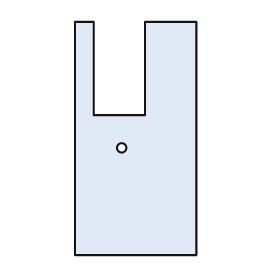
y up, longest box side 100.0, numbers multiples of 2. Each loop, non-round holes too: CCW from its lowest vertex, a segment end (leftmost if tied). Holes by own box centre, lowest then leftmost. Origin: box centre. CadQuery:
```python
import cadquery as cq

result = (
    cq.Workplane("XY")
    .moveTo(-26.0, -50.0)
    .lineTo(26.0, -50.0)
    .lineTo(26.0, 50.0)
    .lineTo(4.0, 50.0)
    .lineTo(4.0, 10.0)
    .lineTo(-18.0, 10.0)
    .lineTo(-18.0, 50.0)
    .lineTo(-26.0, 50.0)
    .close()
    .moveTo(-6.0, -4.0)
    .circle(2.0)
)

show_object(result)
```